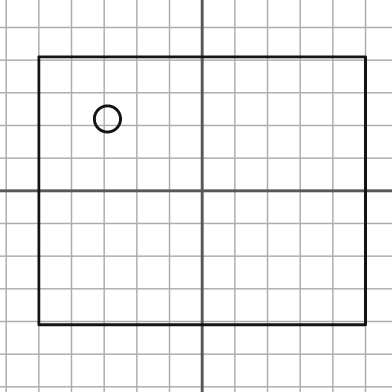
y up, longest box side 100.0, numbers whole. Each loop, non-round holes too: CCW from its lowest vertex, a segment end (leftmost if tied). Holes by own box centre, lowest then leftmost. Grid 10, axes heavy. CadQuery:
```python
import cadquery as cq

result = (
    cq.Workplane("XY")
    .moveTo(-50.0, -41.0)
    .lineTo(50.0, -41.0)
    .lineTo(50.0, 41.0)
    .lineTo(-50.0, 41.0)
    .close()
    .moveTo(-29.0, 22.0)
    .circle(4.0)
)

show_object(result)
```